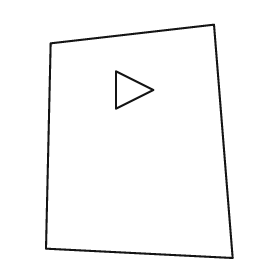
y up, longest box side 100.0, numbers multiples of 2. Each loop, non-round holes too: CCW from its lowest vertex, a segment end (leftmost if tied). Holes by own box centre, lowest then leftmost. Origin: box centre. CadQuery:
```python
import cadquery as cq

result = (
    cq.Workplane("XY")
    .moveTo(40.0, -50.0)
    .lineTo(32.0, 50.0)
    .lineTo(-38.0, 42.0)
    .lineTo(-40.0, -46.0)
    .close()
    .moveTo(-10.0, 14.0)
    .lineTo(6.0, 22.0)
    .lineTo(-10.0, 30.0)
    .close()
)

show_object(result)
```